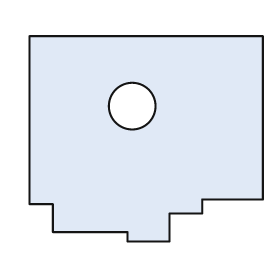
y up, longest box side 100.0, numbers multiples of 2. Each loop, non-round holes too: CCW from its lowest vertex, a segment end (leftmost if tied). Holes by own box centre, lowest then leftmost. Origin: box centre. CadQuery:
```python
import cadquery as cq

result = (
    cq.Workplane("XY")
    .moveTo(-8.0, -44.0)
    .lineTo(10.0, -44.0)
    .lineTo(10.0, -32.0)
    .lineTo(24.0, -32.0)
    .lineTo(24.0, -26.0)
    .lineTo(50.0, -26.0)
    .lineTo(50.0, 44.0)
    .lineTo(-50.0, 44.0)
    .lineTo(-50.0, -28.0)
    .lineTo(-40.0, -28.0)
    .lineTo(-40.0, -40.0)
    .lineTo(-8.0, -40.0)
    .close()
    .moveTo(-6.0, 14.0)
    .circle(10.0)
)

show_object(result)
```